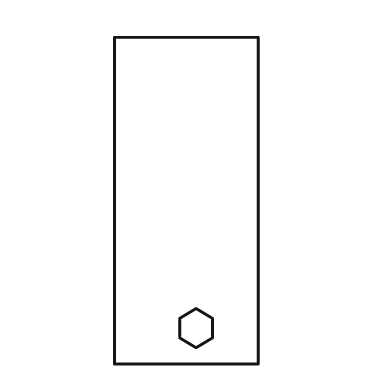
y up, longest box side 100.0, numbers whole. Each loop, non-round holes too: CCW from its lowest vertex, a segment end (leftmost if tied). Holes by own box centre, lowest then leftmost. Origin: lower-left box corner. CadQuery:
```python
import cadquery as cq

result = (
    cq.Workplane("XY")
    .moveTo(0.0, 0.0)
    .lineTo(44.0, 0.0)
    .lineTo(44.0, 100.0)
    .lineTo(0.0, 100.0)
    .close()
    .moveTo(25.0, 5.0)
    .lineTo(30.0, 8.0)
    .lineTo(30.0, 14.0)
    .lineTo(25.0, 17.0)
    .lineTo(20.0, 14.0)
    .lineTo(20.0, 8.0)
    .close()
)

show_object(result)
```